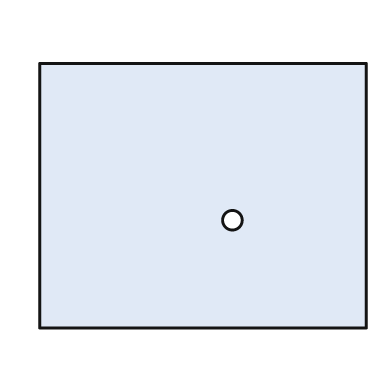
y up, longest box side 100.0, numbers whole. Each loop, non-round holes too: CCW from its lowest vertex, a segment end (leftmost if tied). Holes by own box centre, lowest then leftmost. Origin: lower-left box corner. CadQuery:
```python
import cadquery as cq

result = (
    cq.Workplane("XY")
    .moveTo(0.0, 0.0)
    .lineTo(100.0, 0.0)
    .lineTo(100.0, 81.0)
    .lineTo(0.0, 81.0)
    .close()
    .moveTo(59.0, 33.0)
    .circle(3.0)
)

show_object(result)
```